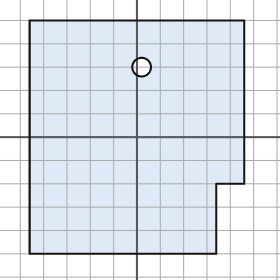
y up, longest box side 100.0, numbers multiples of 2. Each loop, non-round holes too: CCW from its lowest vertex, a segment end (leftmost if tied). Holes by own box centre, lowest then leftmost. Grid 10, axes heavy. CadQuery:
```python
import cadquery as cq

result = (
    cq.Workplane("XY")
    .moveTo(-46.0, -50.0)
    .lineTo(34.0, -50.0)
    .lineTo(34.0, -20.0)
    .lineTo(46.0, -20.0)
    .lineTo(46.0, 50.0)
    .lineTo(-46.0, 50.0)
    .close()
    .moveTo(2.0, 30.0)
    .circle(4.0)
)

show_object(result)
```